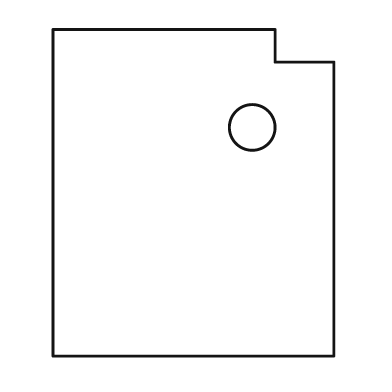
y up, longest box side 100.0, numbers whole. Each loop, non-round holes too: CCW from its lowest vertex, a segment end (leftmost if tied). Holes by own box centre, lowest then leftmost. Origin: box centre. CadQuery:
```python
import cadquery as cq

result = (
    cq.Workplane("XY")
    .moveTo(-43.0, -50.0)
    .lineTo(43.0, -50.0)
    .lineTo(43.0, 40.0)
    .lineTo(25.0, 40.0)
    .lineTo(25.0, 50.0)
    .lineTo(-43.0, 50.0)
    .close()
    .moveTo(18.0, 20.0)
    .circle(7.0)
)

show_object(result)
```